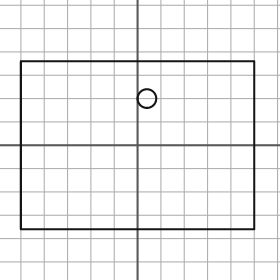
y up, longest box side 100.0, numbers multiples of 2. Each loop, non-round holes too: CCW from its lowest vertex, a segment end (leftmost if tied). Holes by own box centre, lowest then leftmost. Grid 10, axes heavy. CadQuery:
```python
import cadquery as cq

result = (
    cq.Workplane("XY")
    .moveTo(-50.0, -36.0)
    .lineTo(50.0, -36.0)
    .lineTo(50.0, 36.0)
    .lineTo(-50.0, 36.0)
    .close()
    .moveTo(4.0, 20.0)
    .circle(4.0)
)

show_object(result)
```